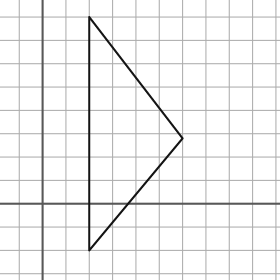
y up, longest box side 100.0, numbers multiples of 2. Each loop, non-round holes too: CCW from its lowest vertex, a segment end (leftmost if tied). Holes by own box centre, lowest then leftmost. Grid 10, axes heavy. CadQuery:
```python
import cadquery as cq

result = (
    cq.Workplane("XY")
    .moveTo(20.0, -20.0)
    .lineTo(60.0, 28.0)
    .lineTo(20.0, 80.0)
    .close()
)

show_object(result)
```